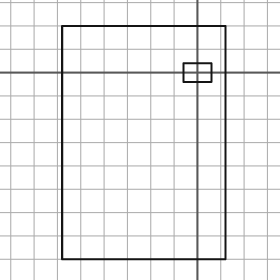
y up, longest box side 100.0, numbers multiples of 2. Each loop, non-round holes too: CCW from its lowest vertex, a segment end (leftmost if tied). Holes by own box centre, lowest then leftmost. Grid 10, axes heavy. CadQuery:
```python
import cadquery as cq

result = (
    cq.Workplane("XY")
    .moveTo(-58.0, -80.0)
    .lineTo(12.0, -80.0)
    .lineTo(12.0, 20.0)
    .lineTo(-58.0, 20.0)
    .close()
    .moveTo(-6.0, -4.0)
    .lineTo(6.0, -4.0)
    .lineTo(6.0, 4.0)
    .lineTo(-6.0, 4.0)
    .close()
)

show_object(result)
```